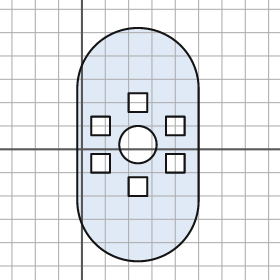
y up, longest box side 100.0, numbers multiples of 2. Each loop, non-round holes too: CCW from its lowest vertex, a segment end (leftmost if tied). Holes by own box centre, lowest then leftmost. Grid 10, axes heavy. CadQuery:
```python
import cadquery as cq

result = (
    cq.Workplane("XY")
    .moveTo(-2.0, -22.0)
    .threePointArc((24.0, -48.0), (50.0, -22.0))
    .lineTo(50.0, 26.0)
    .threePointArc((24.0, 52.0), (-2.0, 26.0))
    .close()
    .moveTo(20.0, -20.0)
    .lineTo(28.0, -20.0)
    .lineTo(28.0, -12.0)
    .lineTo(20.0, -12.0)
    .close()
    .moveTo(4.0, -10.0)
    .lineTo(12.0, -10.0)
    .lineTo(12.0, -2.0)
    .lineTo(4.0, -2.0)
    .close()
    .moveTo(36.0, -10.0)
    .lineTo(44.0, -10.0)
    .lineTo(44.0, -2.0)
    .lineTo(36.0, -2.0)
    .close()
    .moveTo(24.0, 2.0)
    .circle(8.0)
    .moveTo(4.0, 6.0)
    .lineTo(12.0, 6.0)
    .lineTo(12.0, 14.0)
    .lineTo(4.0, 14.0)
    .close()
    .moveTo(36.0, 6.0)
    .lineTo(44.0, 6.0)
    .lineTo(44.0, 14.0)
    .lineTo(36.0, 14.0)
    .close()
    .moveTo(20.0, 16.0)
    .lineTo(28.0, 16.0)
    .lineTo(28.0, 24.0)
    .lineTo(20.0, 24.0)
    .close()
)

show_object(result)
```